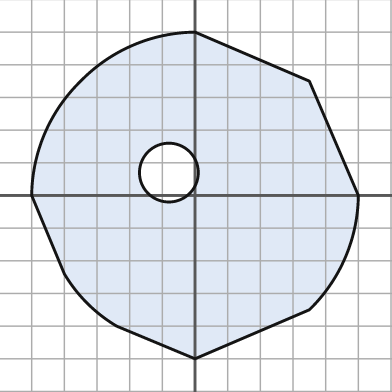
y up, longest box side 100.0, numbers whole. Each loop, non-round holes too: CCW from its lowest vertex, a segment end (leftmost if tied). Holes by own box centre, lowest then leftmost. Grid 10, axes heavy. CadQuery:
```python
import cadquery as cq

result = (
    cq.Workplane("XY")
    .moveTo(0.0, -50.0)
    .lineTo(35.0, -35.0)
    .threePointArc((46.0, -19.0), (50.0, 0.0))
    .lineTo(35.0, 35.0)
    .lineTo(0.0, 50.0)
    .threePointArc((-19.0, 46.0), (-35.0, 35.0))
    .threePointArc((-46.0, 19.0), (-50.0, 0.0))
    .lineTo(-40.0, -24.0)
    .threePointArc((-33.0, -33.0), (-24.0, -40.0))
    .close()
    .moveTo(-8.0, 7.0)
    .circle(9.0)
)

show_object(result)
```